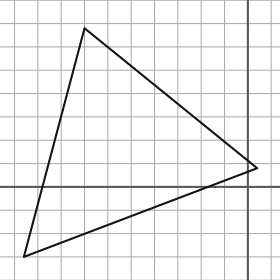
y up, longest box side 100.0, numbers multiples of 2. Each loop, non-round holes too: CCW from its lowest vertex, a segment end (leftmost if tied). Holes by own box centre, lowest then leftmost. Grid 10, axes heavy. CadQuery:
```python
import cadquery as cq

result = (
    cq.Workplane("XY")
    .moveTo(-96.0, -30.0)
    .lineTo(4.0, 8.0)
    .lineTo(-70.0, 68.0)
    .close()
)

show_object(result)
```